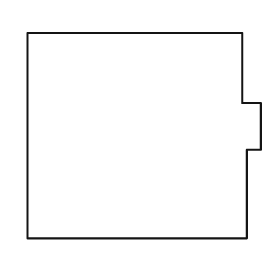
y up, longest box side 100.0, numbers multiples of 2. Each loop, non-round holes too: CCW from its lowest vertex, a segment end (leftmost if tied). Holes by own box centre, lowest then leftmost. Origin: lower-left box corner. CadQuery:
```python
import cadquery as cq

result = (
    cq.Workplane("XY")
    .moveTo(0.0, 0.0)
    .lineTo(94.0, 0.0)
    .lineTo(94.0, 38.0)
    .lineTo(100.0, 38.0)
    .lineTo(100.0, 58.0)
    .lineTo(92.0, 58.0)
    .lineTo(92.0, 88.0)
    .lineTo(0.0, 88.0)
    .close()
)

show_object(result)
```